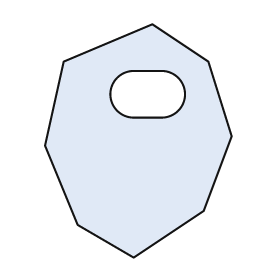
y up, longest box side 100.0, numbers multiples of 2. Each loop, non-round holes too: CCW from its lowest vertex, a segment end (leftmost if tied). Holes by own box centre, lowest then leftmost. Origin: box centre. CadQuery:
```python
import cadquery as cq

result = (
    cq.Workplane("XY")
    .moveTo(-2.0, -50.0)
    .lineTo(28.0, -30.0)
    .lineTo(40.0, 2.0)
    .lineTo(30.0, 34.0)
    .lineTo(6.0, 50.0)
    .lineTo(-32.0, 34.0)
    .lineTo(-40.0, -2.0)
    .lineTo(-26.0, -36.0)
    .close()
    .moveTo(-2.0, 10.0)
    .lineTo(10.0, 10.0)
    .threePointArc((20.0, 20.0), (10.0, 30.0))
    .lineTo(-2.0, 30.0)
    .threePointArc((-12.0, 20.0), (-2.0, 10.0))
    .close()
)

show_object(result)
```